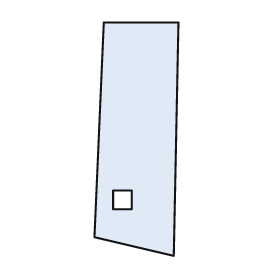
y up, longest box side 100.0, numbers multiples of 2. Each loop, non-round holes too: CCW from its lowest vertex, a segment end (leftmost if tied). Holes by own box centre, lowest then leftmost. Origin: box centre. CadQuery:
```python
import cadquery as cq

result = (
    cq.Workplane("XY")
    .moveTo(16.0, -50.0)
    .lineTo(18.0, 50.0)
    .lineTo(-14.0, 50.0)
    .lineTo(-18.0, -42.0)
    .close()
    .moveTo(-10.0, -30.0)
    .lineTo(-2.0, -30.0)
    .lineTo(-2.0, -22.0)
    .lineTo(-10.0, -22.0)
    .close()
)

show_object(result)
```